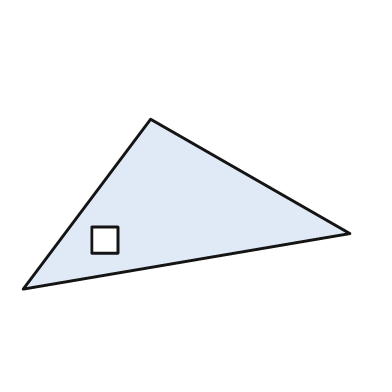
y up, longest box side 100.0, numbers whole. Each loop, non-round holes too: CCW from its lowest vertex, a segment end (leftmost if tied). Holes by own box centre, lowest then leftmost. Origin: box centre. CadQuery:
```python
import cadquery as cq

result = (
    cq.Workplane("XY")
    .moveTo(-50.0, -26.0)
    .lineTo(50.0, -9.0)
    .lineTo(-11.0, 26.0)
    .close()
    .moveTo(-29.0, -15.0)
    .lineTo(-21.0, -15.0)
    .lineTo(-21.0, -7.0)
    .lineTo(-29.0, -7.0)
    .close()
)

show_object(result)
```